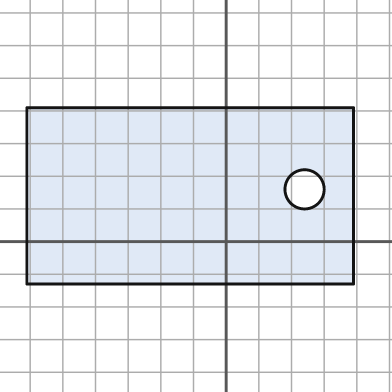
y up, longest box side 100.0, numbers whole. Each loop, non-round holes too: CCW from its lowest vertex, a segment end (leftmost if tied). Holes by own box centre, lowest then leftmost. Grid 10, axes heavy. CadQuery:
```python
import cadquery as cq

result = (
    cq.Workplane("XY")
    .moveTo(-61.0, -13.0)
    .lineTo(39.0, -13.0)
    .lineTo(39.0, 41.0)
    .lineTo(-61.0, 41.0)
    .close()
    .moveTo(24.0, 16.0)
    .circle(6.0)
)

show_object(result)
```